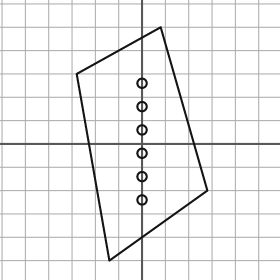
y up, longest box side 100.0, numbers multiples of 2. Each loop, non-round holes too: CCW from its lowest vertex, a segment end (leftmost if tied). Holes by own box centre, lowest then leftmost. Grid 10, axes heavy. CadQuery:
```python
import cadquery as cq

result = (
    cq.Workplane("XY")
    .moveTo(-14.0, -50.0)
    .lineTo(28.0, -20.0)
    .lineTo(8.0, 50.0)
    .lineTo(-28.0, 30.0)
    .close()
    .moveTo(0.0, -24.0)
    .circle(2.0)
    .moveTo(0.0, -14.0)
    .circle(2.0)
    .moveTo(0.0, -4.0)
    .circle(2.0)
    .moveTo(0.0, 6.0)
    .circle(2.0)
    .moveTo(0.0, 16.0)
    .circle(2.0)
    .moveTo(0.0, 26.0)
    .circle(2.0)
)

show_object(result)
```